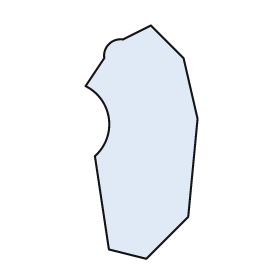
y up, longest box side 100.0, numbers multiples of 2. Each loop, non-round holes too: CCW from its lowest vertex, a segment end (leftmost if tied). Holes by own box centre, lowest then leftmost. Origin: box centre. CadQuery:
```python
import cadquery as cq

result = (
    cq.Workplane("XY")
    .moveTo(2.0, -50.0)
    .lineTo(20.0, -32.0)
    .lineTo(24.0, 10.0)
    .lineTo(18.0, 36.0)
    .lineTo(4.0, 50.0)
    .lineTo(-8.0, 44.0)
    .threePointArc((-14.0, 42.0), (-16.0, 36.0))
    .lineTo(-24.0, 24.0)
    .threePointArc((-14.0, 10.0), (-20.0, -6.0))
    .lineTo(-14.0, -46.0)
    .close()
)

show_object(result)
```